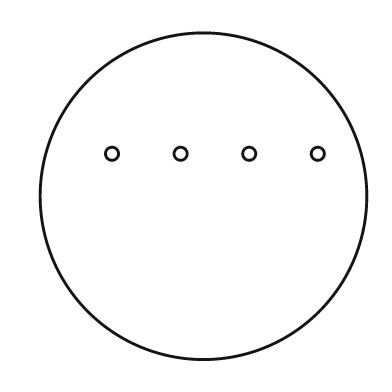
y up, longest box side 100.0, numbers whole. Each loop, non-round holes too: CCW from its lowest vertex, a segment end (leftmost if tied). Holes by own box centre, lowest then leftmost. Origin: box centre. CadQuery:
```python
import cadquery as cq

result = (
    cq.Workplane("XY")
    .moveTo(0.0, 0.0)
    .circle(50.0)
    .moveTo(-28.0, 13.0)
    .circle(2.0)
    .moveTo(-7.0, 13.0)
    .circle(2.0)
    .moveTo(14.0, 13.0)
    .circle(2.0)
    .moveTo(35.0, 13.0)
    .circle(2.0)
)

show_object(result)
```